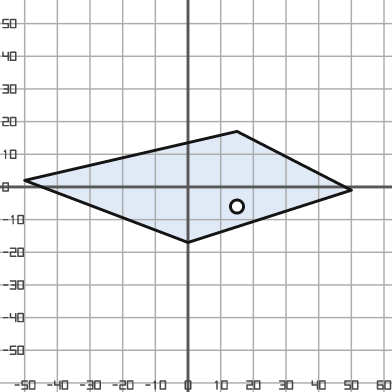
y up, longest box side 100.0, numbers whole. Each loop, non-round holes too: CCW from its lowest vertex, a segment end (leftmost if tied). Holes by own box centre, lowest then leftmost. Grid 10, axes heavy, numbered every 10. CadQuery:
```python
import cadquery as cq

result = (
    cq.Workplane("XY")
    .moveTo(0.0, -17.0)
    .lineTo(50.0, -1.0)
    .lineTo(15.0, 17.0)
    .lineTo(-50.0, 2.0)
    .close()
    .moveTo(15.0, -6.0)
    .circle(2.0)
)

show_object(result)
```